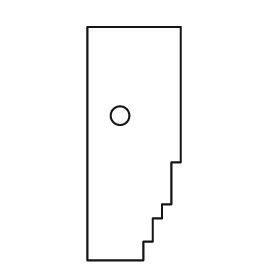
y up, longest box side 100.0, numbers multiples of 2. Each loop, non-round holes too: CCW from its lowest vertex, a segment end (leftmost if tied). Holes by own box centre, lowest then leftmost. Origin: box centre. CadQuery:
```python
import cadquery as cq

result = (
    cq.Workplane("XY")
    .moveTo(-20.0, -50.0)
    .lineTo(4.0, -50.0)
    .lineTo(4.0, -42.0)
    .lineTo(8.0, -42.0)
    .lineTo(8.0, -32.0)
    .lineTo(12.0, -32.0)
    .lineTo(12.0, -26.0)
    .lineTo(16.0, -26.0)
    .lineTo(16.0, -8.0)
    .lineTo(20.0, -8.0)
    .lineTo(20.0, 50.0)
    .lineTo(-20.0, 50.0)
    .close()
    .moveTo(-6.0, 12.0)
    .circle(4.0)
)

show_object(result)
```